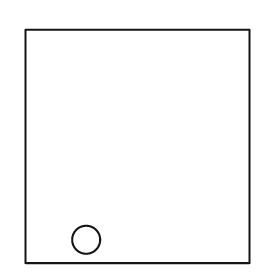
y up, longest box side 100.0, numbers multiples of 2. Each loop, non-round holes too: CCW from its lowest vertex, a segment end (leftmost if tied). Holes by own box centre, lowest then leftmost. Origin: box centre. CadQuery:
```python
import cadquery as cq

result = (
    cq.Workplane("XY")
    .moveTo(-48.0, -50.0)
    .lineTo(48.0, -50.0)
    .lineTo(48.0, 50.0)
    .lineTo(-48.0, 50.0)
    .close()
    .moveTo(-22.0, -40.0)
    .circle(6.0)
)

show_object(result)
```